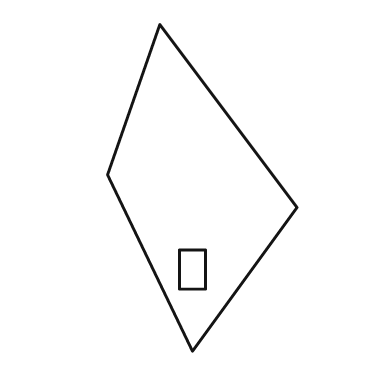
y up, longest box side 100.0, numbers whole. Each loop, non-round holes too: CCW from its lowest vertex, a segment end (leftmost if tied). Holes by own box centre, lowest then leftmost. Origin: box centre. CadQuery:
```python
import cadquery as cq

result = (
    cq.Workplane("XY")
    .moveTo(-3.0, -50.0)
    .lineTo(29.0, -6.0)
    .lineTo(-13.0, 50.0)
    .lineTo(-29.0, 4.0)
    .close()
    .moveTo(-7.0, -31.0)
    .lineTo(1.0, -31.0)
    .lineTo(1.0, -19.0)
    .lineTo(-7.0, -19.0)
    .close()
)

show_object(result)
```